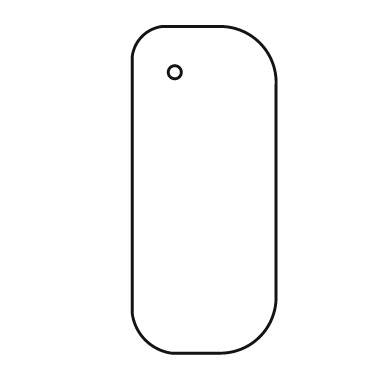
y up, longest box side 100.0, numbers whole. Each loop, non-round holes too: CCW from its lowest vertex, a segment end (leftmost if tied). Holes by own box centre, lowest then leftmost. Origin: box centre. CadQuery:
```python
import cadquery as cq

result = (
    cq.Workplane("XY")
    .moveTo(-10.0, -50.0)
    .lineTo(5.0, -50.0)
    .threePointArc((17.0, -45.0), (22.0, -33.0))
    .lineTo(22.0, 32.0)
    .threePointArc((17.0, 45.0), (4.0, 50.0))
    .lineTo(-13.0, 50.0)
    .threePointArc((-19.0, 47.0), (-22.0, 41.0))
    .lineTo(-22.0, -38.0)
    .threePointArc((-18.0, -46.0), (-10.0, -50.0))
    .close()
    .moveTo(-9.0, 36.0)
    .circle(2.0)
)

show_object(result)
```